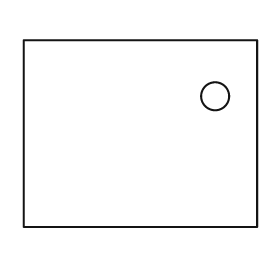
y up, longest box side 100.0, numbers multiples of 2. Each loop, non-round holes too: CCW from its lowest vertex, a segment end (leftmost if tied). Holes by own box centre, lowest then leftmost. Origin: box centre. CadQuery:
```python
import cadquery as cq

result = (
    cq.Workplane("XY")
    .moveTo(-50.0, -40.0)
    .lineTo(50.0, -40.0)
    .lineTo(50.0, 40.0)
    .lineTo(-50.0, 40.0)
    .close()
    .moveTo(32.0, 16.0)
    .circle(6.0)
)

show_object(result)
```